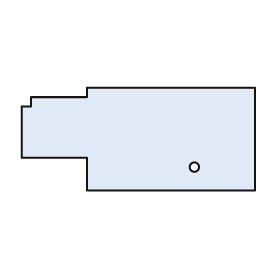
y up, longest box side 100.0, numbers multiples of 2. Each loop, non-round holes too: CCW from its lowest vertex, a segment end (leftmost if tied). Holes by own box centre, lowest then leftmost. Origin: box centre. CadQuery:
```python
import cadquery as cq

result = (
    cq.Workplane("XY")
    .moveTo(-22.0, -22.0)
    .lineTo(50.0, -22.0)
    .lineTo(50.0, 22.0)
    .lineTo(-22.0, 22.0)
    .lineTo(-22.0, 18.0)
    .lineTo(-46.0, 18.0)
    .lineTo(-46.0, 14.0)
    .lineTo(-50.0, 14.0)
    .lineTo(-50.0, -8.0)
    .lineTo(-22.0, -8.0)
    .close()
    .moveTo(24.0, -12.0)
    .circle(2.0)
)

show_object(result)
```